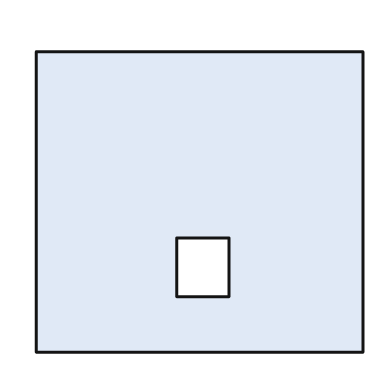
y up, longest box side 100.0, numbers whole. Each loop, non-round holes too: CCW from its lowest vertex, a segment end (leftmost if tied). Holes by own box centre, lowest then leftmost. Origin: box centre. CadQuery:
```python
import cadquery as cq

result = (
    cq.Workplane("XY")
    .moveTo(-50.0, -46.0)
    .lineTo(50.0, -46.0)
    .lineTo(50.0, 46.0)
    .lineTo(-50.0, 46.0)
    .close()
    .moveTo(-7.0, -29.0)
    .lineTo(9.0, -29.0)
    .lineTo(9.0, -11.0)
    .lineTo(-7.0, -11.0)
    .close()
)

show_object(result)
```